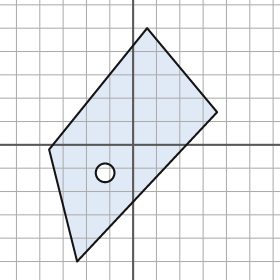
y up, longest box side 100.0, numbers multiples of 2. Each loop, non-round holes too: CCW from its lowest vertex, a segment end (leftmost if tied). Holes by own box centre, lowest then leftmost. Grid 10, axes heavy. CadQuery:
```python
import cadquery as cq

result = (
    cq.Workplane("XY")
    .moveTo(-24.0, -50.0)
    .lineTo(36.0, 14.0)
    .lineTo(6.0, 50.0)
    .lineTo(-36.0, -2.0)
    .close()
    .moveTo(-12.0, -12.0)
    .circle(4.0)
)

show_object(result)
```